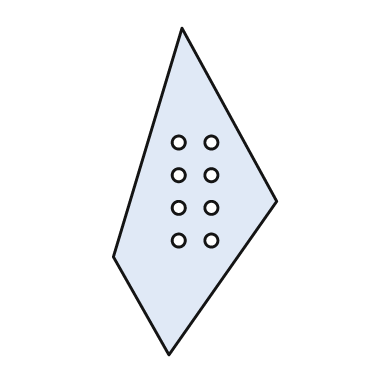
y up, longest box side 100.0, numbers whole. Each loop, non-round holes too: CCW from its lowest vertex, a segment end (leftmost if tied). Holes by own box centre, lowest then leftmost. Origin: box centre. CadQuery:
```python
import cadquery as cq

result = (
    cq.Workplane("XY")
    .moveTo(-8.0, -50.0)
    .lineTo(25.0, -3.0)
    .lineTo(-4.0, 50.0)
    .lineTo(-25.0, -20.0)
    .close()
    .moveTo(-5.0, -15.0)
    .circle(2.0)
    .moveTo(5.0, -15.0)
    .circle(2.0)
    .moveTo(-5.0, -5.0)
    .circle(2.0)
    .moveTo(5.0, -5.0)
    .circle(2.0)
    .moveTo(-5.0, 5.0)
    .circle(2.0)
    .moveTo(5.0, 5.0)
    .circle(2.0)
    .moveTo(-5.0, 15.0)
    .circle(2.0)
    .moveTo(5.0, 15.0)
    .circle(2.0)
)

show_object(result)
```